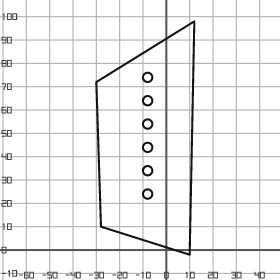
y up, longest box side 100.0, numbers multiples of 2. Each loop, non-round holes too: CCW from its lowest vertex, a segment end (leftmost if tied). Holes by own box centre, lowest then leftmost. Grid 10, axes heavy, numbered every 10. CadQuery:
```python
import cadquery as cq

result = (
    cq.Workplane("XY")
    .moveTo(10.0, -2.0)
    .lineTo(12.0, 98.0)
    .lineTo(-30.0, 72.0)
    .lineTo(-28.0, 10.0)
    .close()
    .moveTo(-8.0, 24.0)
    .circle(2.0)
    .moveTo(-8.0, 34.0)
    .circle(2.0)
    .moveTo(-8.0, 44.0)
    .circle(2.0)
    .moveTo(-8.0, 54.0)
    .circle(2.0)
    .moveTo(-8.0, 64.0)
    .circle(2.0)
    .moveTo(-8.0, 74.0)
    .circle(2.0)
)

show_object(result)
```